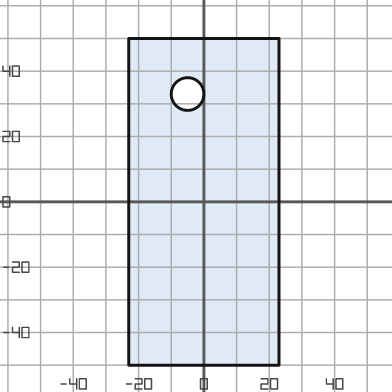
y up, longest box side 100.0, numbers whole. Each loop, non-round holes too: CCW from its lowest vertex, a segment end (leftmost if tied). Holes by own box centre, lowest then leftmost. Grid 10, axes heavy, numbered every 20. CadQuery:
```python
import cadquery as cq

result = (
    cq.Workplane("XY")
    .moveTo(-23.0, -50.0)
    .lineTo(23.0, -50.0)
    .lineTo(23.0, 50.0)
    .lineTo(-23.0, 50.0)
    .close()
    .moveTo(-5.0, 33.0)
    .circle(5.0)
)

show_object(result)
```